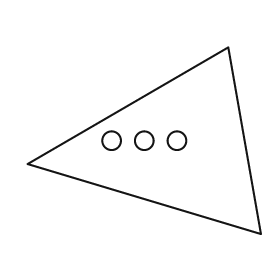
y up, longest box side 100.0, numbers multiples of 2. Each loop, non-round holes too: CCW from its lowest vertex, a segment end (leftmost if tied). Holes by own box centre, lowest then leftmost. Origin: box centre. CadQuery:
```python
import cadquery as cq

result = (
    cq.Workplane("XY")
    .moveTo(50.0, -40.0)
    .lineTo(36.0, 40.0)
    .lineTo(-50.0, -10.0)
    .close()
    .moveTo(-14.0, 0.0)
    .circle(4.0)
    .moveTo(0.0, 0.0)
    .circle(4.0)
    .moveTo(14.0, 0.0)
    .circle(4.0)
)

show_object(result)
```